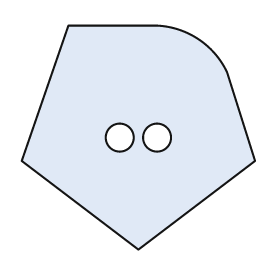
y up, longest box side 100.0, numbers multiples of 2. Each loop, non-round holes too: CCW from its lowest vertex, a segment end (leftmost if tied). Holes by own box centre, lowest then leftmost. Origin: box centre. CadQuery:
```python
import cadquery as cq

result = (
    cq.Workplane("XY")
    .moveTo(0.0, -48.0)
    .lineTo(50.0, -10.0)
    .lineTo(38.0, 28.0)
    .threePointArc((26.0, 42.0), (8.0, 48.0))
    .lineTo(-30.0, 48.0)
    .lineTo(-50.0, -10.0)
    .close()
    .moveTo(-8.0, 0.0)
    .circle(6.0)
    .moveTo(8.0, 0.0)
    .circle(6.0)
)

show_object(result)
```